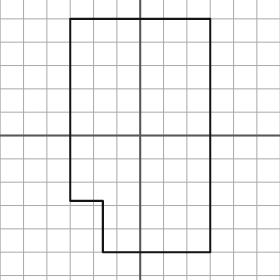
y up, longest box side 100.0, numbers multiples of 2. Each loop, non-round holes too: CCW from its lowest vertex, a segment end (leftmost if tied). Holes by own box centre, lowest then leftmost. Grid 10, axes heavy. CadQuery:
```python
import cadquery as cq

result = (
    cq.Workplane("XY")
    .moveTo(-16.0, -50.0)
    .lineTo(30.0, -50.0)
    .lineTo(30.0, 50.0)
    .lineTo(-30.0, 50.0)
    .lineTo(-30.0, -28.0)
    .lineTo(-16.0, -28.0)
    .close()
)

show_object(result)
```